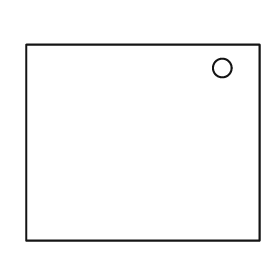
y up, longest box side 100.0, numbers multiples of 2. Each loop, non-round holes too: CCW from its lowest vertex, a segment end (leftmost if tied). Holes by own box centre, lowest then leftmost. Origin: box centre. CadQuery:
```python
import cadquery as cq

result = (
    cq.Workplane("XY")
    .moveTo(-50.0, -42.0)
    .lineTo(50.0, -42.0)
    .lineTo(50.0, 42.0)
    .lineTo(-50.0, 42.0)
    .close()
    .moveTo(34.0, 32.0)
    .circle(4.0)
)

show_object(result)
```